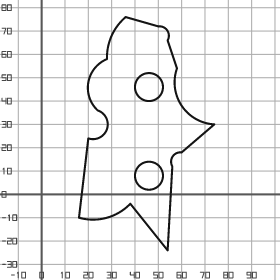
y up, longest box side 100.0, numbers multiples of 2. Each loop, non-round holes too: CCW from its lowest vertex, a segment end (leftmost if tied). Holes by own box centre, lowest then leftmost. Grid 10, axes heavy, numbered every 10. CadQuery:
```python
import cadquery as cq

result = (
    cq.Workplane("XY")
    .moveTo(54.0, -24.0)
    .lineTo(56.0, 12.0)
    .threePointArc((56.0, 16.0), (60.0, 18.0))
    .lineTo(74.0, 30.0)
    .threePointArc((60.0, 38.0), (58.0, 54.0))
    .lineTo(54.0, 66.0)
    .threePointArc((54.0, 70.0), (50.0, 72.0))
    .lineTo(36.0, 76.0)
    .threePointArc((30.0, 68.0), (28.0, 58.0))
    .threePointArc((20.0, 48.0), (24.0, 36.0))
    .threePointArc((28.0, 28.0), (20.0, 24.0))
    .lineTo(16.0, -10.0)
    .threePointArc((28.0, -10.0), (38.0, -4.0))
    .close()
    .moveTo(46.0, 8.0)
    .circle(6.0)
    .moveTo(46.0, 46.0)
    .circle(6.0)
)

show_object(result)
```